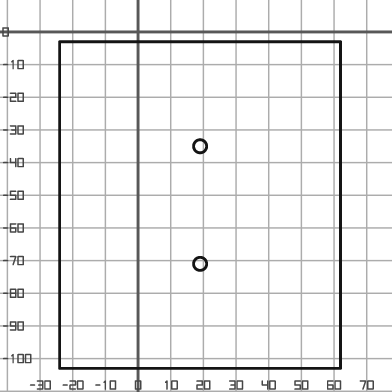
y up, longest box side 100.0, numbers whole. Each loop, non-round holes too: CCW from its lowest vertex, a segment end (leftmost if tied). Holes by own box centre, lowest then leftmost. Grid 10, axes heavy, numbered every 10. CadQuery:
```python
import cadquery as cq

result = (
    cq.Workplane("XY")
    .moveTo(-24.0, -103.0)
    .lineTo(62.0, -103.0)
    .lineTo(62.0, -3.0)
    .lineTo(-24.0, -3.0)
    .close()
    .moveTo(19.0, -71.0)
    .circle(2.0)
    .moveTo(19.0, -35.0)
    .circle(2.0)
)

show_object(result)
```